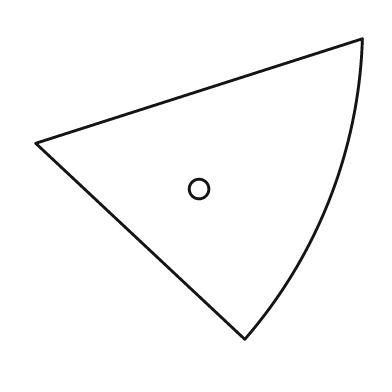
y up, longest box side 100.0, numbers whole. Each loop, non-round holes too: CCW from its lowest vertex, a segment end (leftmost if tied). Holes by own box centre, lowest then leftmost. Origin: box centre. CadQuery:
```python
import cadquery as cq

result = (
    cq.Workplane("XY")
    .moveTo(14.0, -46.0)
    .threePointArc((40.0, -3.0), (50.0, 46.0))
    .lineTo(-50.0, 14.0)
    .close()
    .moveTo(0.0, 0.0)
    .circle(3.0)
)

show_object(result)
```